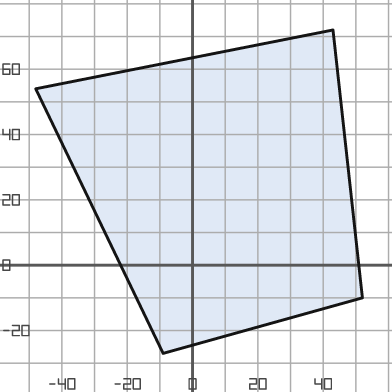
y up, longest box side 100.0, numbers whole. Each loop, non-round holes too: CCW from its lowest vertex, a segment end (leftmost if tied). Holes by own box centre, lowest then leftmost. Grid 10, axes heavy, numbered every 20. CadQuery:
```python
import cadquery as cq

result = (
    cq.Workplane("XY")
    .moveTo(-9.0, -27.0)
    .lineTo(52.0, -10.0)
    .lineTo(43.0, 72.0)
    .lineTo(-48.0, 54.0)
    .close()
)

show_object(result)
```